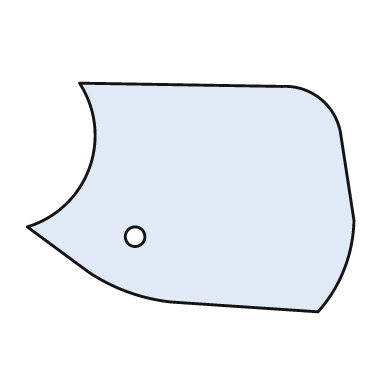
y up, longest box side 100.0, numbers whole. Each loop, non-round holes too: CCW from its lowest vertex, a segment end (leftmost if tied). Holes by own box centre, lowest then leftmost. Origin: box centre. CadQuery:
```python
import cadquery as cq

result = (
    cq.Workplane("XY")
    .moveTo(39.0, -35.0)
    .threePointArc((47.0, -22.0), (50.0, -7.0))
    .lineTo(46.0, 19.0)
    .threePointArc((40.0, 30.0), (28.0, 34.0))
    .lineTo(-34.0, 35.0)
    .threePointArc((-31.0, 9.0), (-50.0, -9.0))
    .lineTo(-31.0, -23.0)
    .threePointArc((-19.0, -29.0), (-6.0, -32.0))
    .close()
    .moveTo(-17.0, -12.0)
    .circle(3.0)
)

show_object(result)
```